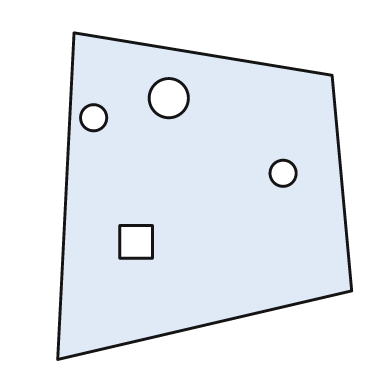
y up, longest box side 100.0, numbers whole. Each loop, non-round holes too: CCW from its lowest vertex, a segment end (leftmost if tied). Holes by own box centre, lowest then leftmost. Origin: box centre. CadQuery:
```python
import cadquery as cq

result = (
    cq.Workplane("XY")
    .moveTo(-45.0, -50.0)
    .lineTo(45.0, -29.0)
    .lineTo(39.0, 37.0)
    .lineTo(-40.0, 50.0)
    .close()
    .moveTo(-26.0, -19.0)
    .lineTo(-16.0, -19.0)
    .lineTo(-16.0, -9.0)
    .lineTo(-26.0, -9.0)
    .close()
    .moveTo(24.0, 7.0)
    .circle(4.0)
    .moveTo(-34.0, 24.0)
    .circle(4.0)
    .moveTo(-11.0, 30.0)
    .circle(6.0)
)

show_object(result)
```